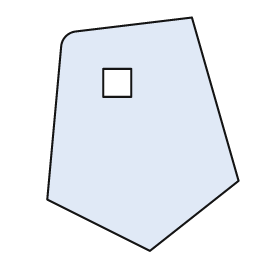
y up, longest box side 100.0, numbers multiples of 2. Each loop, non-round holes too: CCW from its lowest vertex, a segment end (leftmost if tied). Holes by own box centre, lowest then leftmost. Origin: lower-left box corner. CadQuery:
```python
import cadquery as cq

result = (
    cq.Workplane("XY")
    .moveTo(44.0, 0.0)
    .lineTo(82.0, 30.0)
    .lineTo(62.0, 100.0)
    .lineTo(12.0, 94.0)
    .threePointArc((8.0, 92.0), (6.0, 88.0))
    .lineTo(0.0, 22.0)
    .close()
    .moveTo(24.0, 66.0)
    .lineTo(36.0, 66.0)
    .lineTo(36.0, 78.0)
    .lineTo(24.0, 78.0)
    .close()
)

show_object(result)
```